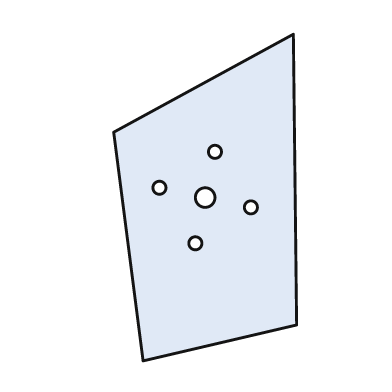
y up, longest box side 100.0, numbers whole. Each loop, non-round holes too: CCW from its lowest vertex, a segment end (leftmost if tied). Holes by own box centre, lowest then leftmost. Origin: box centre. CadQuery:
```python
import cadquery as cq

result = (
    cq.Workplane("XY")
    .moveTo(-19.0, -50.0)
    .lineTo(28.0, -39.0)
    .lineTo(27.0, 50.0)
    .lineTo(-28.0, 20.0)
    .close()
    .moveTo(-3.0, -14.0)
    .circle(2.0)
    .moveTo(14.0, -3.0)
    .circle(2.0)
    .moveTo(0.0, 0.0)
    .circle(3.0)
    .moveTo(-14.0, 3.0)
    .circle(2.0)
    .moveTo(3.0, 14.0)
    .circle(2.0)
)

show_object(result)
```